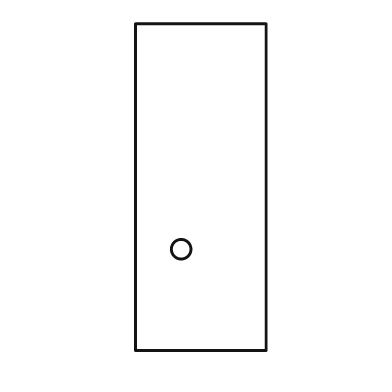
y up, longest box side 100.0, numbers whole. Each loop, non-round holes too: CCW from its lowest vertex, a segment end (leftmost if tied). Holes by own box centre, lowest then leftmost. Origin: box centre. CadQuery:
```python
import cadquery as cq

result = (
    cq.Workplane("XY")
    .moveTo(-20.0, -50.0)
    .lineTo(20.0, -50.0)
    .lineTo(20.0, 50.0)
    .lineTo(-20.0, 50.0)
    .close()
    .moveTo(-6.0, -19.0)
    .circle(3.0)
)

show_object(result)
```